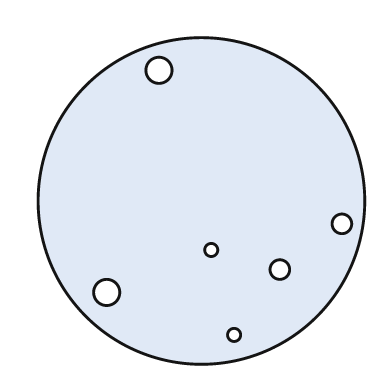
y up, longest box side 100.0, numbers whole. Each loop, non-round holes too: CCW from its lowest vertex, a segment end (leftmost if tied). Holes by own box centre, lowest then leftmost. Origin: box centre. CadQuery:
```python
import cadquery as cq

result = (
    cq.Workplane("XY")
    .moveTo(0.0, 0.0)
    .circle(50.0)
    .moveTo(10.0, -41.0)
    .circle(2.0)
    .moveTo(-29.0, -28.0)
    .circle(4.0)
    .moveTo(24.0, -21.0)
    .circle(3.0)
    .moveTo(3.0, -15.0)
    .circle(2.0)
    .moveTo(43.0, -7.0)
    .circle(3.0)
    .moveTo(-13.0, 40.0)
    .circle(4.0)
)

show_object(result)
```